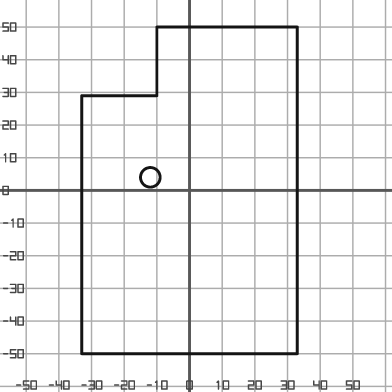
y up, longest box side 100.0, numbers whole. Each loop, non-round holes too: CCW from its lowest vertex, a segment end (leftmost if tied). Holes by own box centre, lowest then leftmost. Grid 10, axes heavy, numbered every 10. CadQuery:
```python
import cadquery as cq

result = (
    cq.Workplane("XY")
    .moveTo(-33.0, -50.0)
    .lineTo(33.0, -50.0)
    .lineTo(33.0, 50.0)
    .lineTo(-10.0, 50.0)
    .lineTo(-10.0, 29.0)
    .lineTo(-33.0, 29.0)
    .close()
    .moveTo(-12.0, 4.0)
    .circle(3.0)
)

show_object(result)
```